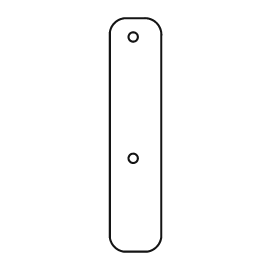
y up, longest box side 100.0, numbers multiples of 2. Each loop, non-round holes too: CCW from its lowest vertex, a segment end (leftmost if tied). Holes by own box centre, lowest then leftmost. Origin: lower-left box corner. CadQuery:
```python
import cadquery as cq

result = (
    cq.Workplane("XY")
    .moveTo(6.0, 0.0)
    .lineTo(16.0, 0.0)
    .threePointArc((20.0, 2.0), (22.0, 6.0))
    .lineTo(22.0, 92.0)
    .threePointArc((20.0, 98.0), (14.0, 100.0))
    .lineTo(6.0, 100.0)
    .threePointArc((2.0, 98.0), (0.0, 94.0))
    .lineTo(0.0, 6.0)
    .threePointArc((2.0, 2.0), (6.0, 0.0))
    .close()
    .moveTo(10.0, 40.0)
    .circle(2.0)
    .moveTo(10.0, 92.0)
    .circle(2.0)
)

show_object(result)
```